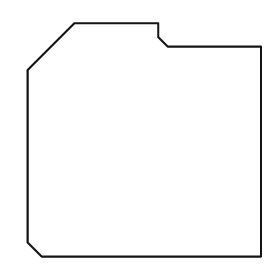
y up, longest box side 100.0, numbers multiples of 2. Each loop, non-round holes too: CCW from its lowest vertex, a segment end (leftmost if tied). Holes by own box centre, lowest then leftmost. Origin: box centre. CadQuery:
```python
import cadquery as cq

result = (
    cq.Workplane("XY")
    .moveTo(-44.0, -50.0)
    .lineTo(50.0, -50.0)
    .lineTo(50.0, 40.0)
    .lineTo(10.0, 40.0)
    .lineTo(6.0, 44.0)
    .lineTo(6.0, 50.0)
    .lineTo(-30.0, 50.0)
    .lineTo(-50.0, 30.0)
    .lineTo(-50.0, -44.0)
    .close()
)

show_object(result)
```